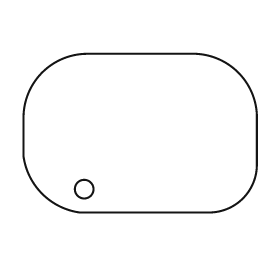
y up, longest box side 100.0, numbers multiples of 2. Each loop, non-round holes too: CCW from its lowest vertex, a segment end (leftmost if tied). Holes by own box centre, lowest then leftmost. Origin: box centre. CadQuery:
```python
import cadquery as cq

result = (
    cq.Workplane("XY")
    .moveTo(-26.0, -34.0)
    .lineTo(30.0, -34.0)
    .threePointArc((44.0, -28.0), (50.0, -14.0))
    .lineTo(50.0, 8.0)
    .threePointArc((42.0, 26.0), (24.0, 34.0))
    .lineTo(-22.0, 34.0)
    .threePointArc((-42.0, 26.0), (-50.0, 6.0))
    .lineTo(-50.0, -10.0)
    .threePointArc((-42.0, -26.0), (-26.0, -34.0))
    .close()
    .moveTo(-24.0, -24.0)
    .circle(4.0)
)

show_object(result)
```